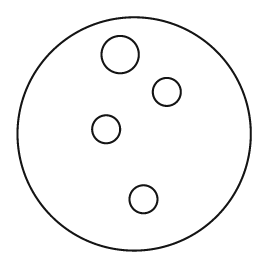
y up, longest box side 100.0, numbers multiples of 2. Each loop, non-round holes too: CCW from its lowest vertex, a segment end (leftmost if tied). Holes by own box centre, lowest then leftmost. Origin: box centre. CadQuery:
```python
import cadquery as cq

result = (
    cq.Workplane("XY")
    .moveTo(0.0, 0.0)
    .circle(50.0)
    .moveTo(4.0, -28.0)
    .circle(6.0)
    .moveTo(-12.0, 2.0)
    .circle(6.0)
    .moveTo(14.0, 18.0)
    .circle(6.0)
    .moveTo(-6.0, 34.0)
    .circle(8.0)
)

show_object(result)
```